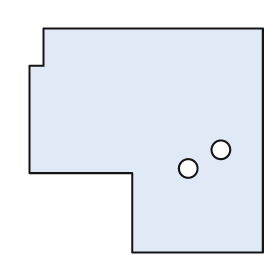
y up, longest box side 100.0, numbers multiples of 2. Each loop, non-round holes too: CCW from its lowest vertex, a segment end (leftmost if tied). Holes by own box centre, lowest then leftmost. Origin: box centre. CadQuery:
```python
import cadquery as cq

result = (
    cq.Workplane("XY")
    .moveTo(-6.0, -48.0)
    .lineTo(50.0, -48.0)
    .lineTo(50.0, 48.0)
    .lineTo(-44.0, 48.0)
    .lineTo(-44.0, 32.0)
    .lineTo(-50.0, 32.0)
    .lineTo(-50.0, -14.0)
    .lineTo(-6.0, -14.0)
    .close()
    .moveTo(18.0, -12.0)
    .circle(4.0)
    .moveTo(32.0, -4.0)
    .circle(4.0)
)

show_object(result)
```